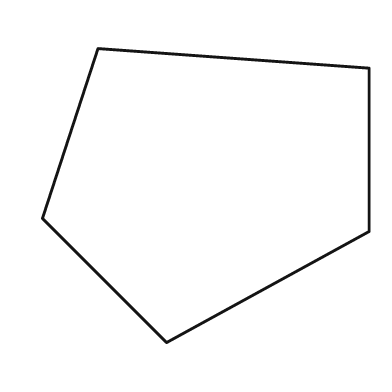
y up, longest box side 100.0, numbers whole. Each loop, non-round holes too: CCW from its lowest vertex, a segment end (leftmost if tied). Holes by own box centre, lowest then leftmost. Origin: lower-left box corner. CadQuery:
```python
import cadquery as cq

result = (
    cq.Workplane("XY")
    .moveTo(38.0, 0.0)
    .lineTo(100.0, 34.0)
    .lineTo(100.0, 84.0)
    .lineTo(17.0, 90.0)
    .lineTo(0.0, 38.0)
    .close()
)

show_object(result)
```